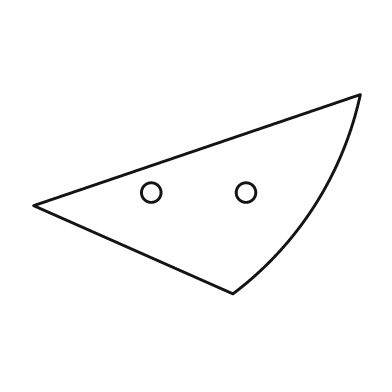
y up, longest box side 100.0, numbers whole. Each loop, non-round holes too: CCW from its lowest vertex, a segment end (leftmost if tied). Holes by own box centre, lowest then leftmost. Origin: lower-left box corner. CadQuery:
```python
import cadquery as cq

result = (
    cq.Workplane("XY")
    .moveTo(61.0, 0.0)
    .threePointArc((86.0, 27.0), (100.0, 61.0))
    .lineTo(0.0, 27.0)
    .close()
    .moveTo(36.0, 31.0)
    .circle(3.0)
    .moveTo(65.0, 31.0)
    .circle(3.0)
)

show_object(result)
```